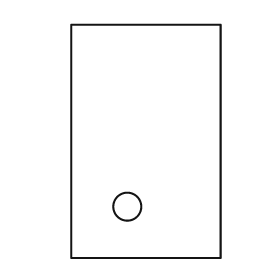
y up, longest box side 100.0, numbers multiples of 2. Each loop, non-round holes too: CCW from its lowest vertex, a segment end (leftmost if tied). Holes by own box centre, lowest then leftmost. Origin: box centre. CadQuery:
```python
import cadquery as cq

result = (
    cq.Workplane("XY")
    .moveTo(-32.0, -50.0)
    .lineTo(32.0, -50.0)
    .lineTo(32.0, 50.0)
    .lineTo(-32.0, 50.0)
    .close()
    .moveTo(-8.0, -28.0)
    .circle(6.0)
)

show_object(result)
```